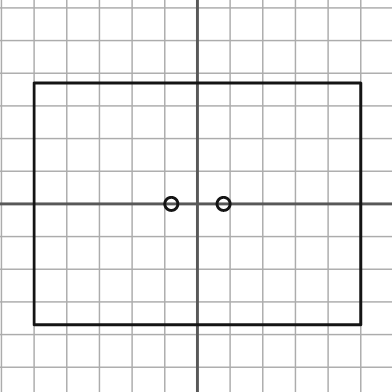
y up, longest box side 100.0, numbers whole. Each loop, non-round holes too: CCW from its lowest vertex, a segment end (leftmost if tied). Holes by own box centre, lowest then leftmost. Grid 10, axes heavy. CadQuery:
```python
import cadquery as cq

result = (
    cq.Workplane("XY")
    .moveTo(-50.0, -37.0)
    .lineTo(50.0, -37.0)
    .lineTo(50.0, 37.0)
    .lineTo(-50.0, 37.0)
    .close()
    .moveTo(-8.0, 0.0)
    .circle(2.0)
    .moveTo(8.0, 0.0)
    .circle(2.0)
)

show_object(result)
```